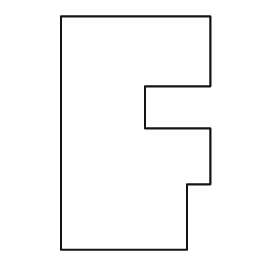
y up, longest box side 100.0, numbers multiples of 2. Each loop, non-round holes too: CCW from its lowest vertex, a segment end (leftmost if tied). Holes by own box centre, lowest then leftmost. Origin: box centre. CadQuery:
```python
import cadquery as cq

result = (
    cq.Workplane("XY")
    .moveTo(-32.0, -50.0)
    .lineTo(22.0, -50.0)
    .lineTo(22.0, -22.0)
    .lineTo(32.0, -22.0)
    .lineTo(32.0, 2.0)
    .lineTo(4.0, 2.0)
    .lineTo(4.0, 20.0)
    .lineTo(32.0, 20.0)
    .lineTo(32.0, 50.0)
    .lineTo(-32.0, 50.0)
    .close()
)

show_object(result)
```